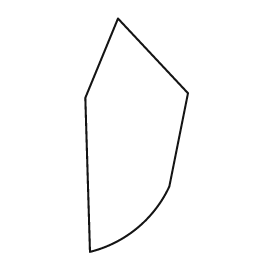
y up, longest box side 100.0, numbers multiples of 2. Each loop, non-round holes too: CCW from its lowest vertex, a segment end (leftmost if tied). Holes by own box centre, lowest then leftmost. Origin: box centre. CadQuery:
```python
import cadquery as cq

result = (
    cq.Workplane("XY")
    .moveTo(-20.0, -50.0)
    .threePointArc((0.0, -40.0), (14.0, -22.0))
    .lineTo(22.0, 18.0)
    .lineTo(-8.0, 50.0)
    .lineTo(-22.0, 16.0)
    .close()
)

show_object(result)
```